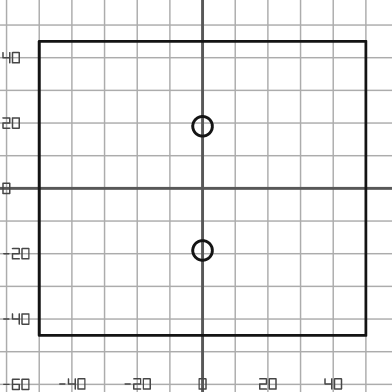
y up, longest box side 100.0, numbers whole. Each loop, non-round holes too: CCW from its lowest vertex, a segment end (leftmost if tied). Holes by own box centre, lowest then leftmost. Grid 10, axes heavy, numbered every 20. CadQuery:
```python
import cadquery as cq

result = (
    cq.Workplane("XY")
    .moveTo(-50.0, -45.0)
    .lineTo(50.0, -45.0)
    .lineTo(50.0, 45.0)
    .lineTo(-50.0, 45.0)
    .close()
    .moveTo(0.0, -19.0)
    .circle(3.0)
    .moveTo(0.0, 19.0)
    .circle(3.0)
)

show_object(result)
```